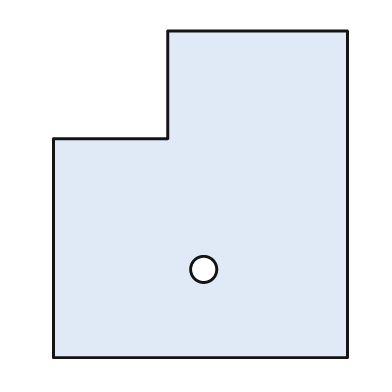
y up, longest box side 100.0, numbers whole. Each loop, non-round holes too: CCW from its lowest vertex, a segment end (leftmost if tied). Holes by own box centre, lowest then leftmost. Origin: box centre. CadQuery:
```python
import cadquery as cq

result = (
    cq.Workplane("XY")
    .moveTo(-45.0, -50.0)
    .lineTo(45.0, -50.0)
    .lineTo(45.0, 50.0)
    .lineTo(-10.0, 50.0)
    .lineTo(-10.0, 17.0)
    .lineTo(-45.0, 17.0)
    .close()
    .moveTo(1.0, -23.0)
    .circle(4.0)
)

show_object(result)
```